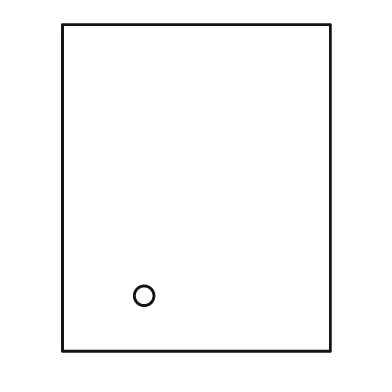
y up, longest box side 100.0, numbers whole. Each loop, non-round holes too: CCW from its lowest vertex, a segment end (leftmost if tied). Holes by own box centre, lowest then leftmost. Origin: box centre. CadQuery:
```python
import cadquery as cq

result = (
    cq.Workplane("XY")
    .moveTo(-41.0, -50.0)
    .lineTo(41.0, -50.0)
    .lineTo(41.0, 50.0)
    .lineTo(-41.0, 50.0)
    .close()
    .moveTo(-16.0, -33.0)
    .circle(3.0)
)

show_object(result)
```